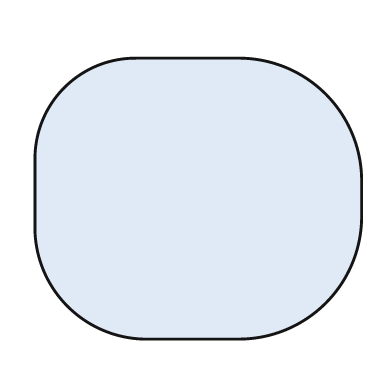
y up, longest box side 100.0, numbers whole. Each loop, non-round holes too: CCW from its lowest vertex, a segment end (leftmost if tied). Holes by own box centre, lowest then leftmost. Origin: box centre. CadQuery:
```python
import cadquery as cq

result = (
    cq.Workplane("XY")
    .moveTo(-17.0, -43.0)
    .lineTo(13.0, -43.0)
    .threePointArc((39.0, -32.0), (50.0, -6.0))
    .lineTo(50.0, 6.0)
    .threePointArc((39.0, 32.0), (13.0, 43.0))
    .lineTo(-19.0, 43.0)
    .threePointArc((-41.0, 34.0), (-50.0, 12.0))
    .lineTo(-50.0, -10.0)
    .threePointArc((-40.0, -33.0), (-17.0, -43.0))
    .close()
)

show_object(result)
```